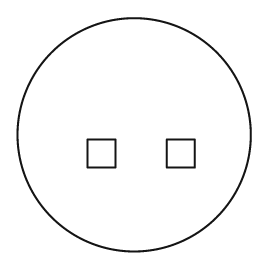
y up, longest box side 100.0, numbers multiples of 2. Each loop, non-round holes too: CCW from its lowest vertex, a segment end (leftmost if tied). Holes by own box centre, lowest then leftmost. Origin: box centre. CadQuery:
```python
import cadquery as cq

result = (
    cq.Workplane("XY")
    .moveTo(0.0, 0.0)
    .circle(50.0)
    .moveTo(-20.0, -14.0)
    .lineTo(-8.0, -14.0)
    .lineTo(-8.0, -2.0)
    .lineTo(-20.0, -2.0)
    .close()
    .moveTo(14.0, -14.0)
    .lineTo(26.0, -14.0)
    .lineTo(26.0, -2.0)
    .lineTo(14.0, -2.0)
    .close()
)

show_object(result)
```